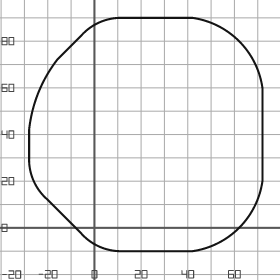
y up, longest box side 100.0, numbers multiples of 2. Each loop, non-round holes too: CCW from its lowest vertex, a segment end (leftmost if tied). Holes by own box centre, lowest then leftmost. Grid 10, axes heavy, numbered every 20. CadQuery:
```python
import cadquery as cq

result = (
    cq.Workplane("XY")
    .moveTo(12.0, -10.0)
    .lineTo(42.0, -10.0)
    .threePointArc((62.0, 0.0), (72.0, 20.0))
    .lineTo(72.0, 60.0)
    .threePointArc((62.0, 80.0), (42.0, 90.0))
    .lineTo(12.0, 90.0)
    .threePointArc((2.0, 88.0), (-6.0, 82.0))
    .lineTo(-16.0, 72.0)
    .threePointArc((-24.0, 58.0), (-28.0, 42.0))
    .lineTo(-28.0, 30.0)
    .threePointArc((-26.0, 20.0), (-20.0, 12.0))
    .lineTo(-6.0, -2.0)
    .threePointArc((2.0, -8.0), (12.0, -10.0))
    .close()
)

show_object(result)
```